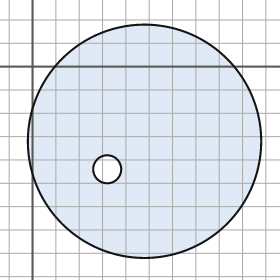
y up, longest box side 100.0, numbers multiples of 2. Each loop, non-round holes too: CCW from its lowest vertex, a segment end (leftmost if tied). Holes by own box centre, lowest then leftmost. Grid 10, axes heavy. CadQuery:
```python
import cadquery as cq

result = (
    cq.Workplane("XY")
    .moveTo(48.0, -32.0)
    .circle(50.0)
    .moveTo(32.0, -44.0)
    .circle(6.0)
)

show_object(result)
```